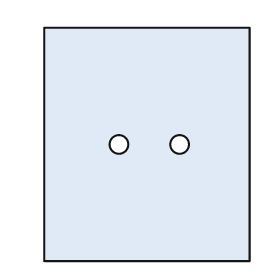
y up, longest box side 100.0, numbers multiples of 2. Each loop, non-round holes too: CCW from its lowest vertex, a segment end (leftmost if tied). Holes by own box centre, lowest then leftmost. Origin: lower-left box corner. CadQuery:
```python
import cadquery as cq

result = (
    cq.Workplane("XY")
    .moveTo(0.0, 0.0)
    .lineTo(88.0, 0.0)
    .lineTo(88.0, 100.0)
    .lineTo(0.0, 100.0)
    .close()
    .moveTo(32.0, 50.0)
    .circle(4.0)
    .moveTo(58.0, 50.0)
    .circle(4.0)
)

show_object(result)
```